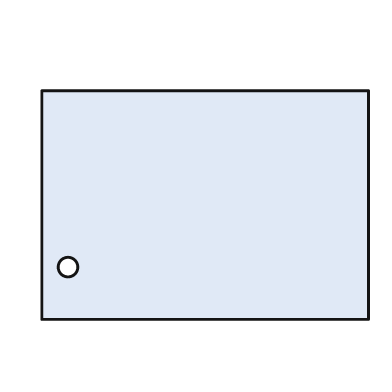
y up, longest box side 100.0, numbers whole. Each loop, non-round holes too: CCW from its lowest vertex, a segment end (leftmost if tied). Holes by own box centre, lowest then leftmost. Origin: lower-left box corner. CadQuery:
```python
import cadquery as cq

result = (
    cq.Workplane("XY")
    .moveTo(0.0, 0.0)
    .lineTo(100.0, 0.0)
    .lineTo(100.0, 70.0)
    .lineTo(0.0, 70.0)
    .close()
    .moveTo(8.0, 16.0)
    .circle(3.0)
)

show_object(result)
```